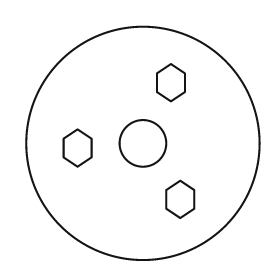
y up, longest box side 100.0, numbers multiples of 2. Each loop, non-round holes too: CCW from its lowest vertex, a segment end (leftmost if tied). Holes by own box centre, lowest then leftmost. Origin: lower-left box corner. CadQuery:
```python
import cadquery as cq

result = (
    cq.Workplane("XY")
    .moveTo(50.0, 50.0)
    .circle(50.0)
    .moveTo(66.0, 18.0)
    .lineTo(72.0, 22.0)
    .lineTo(72.0, 30.0)
    .lineTo(66.0, 34.0)
    .lineTo(60.0, 30.0)
    .lineTo(60.0, 22.0)
    .close()
    .moveTo(22.0, 40.0)
    .lineTo(28.0, 44.0)
    .lineTo(28.0, 52.0)
    .lineTo(22.0, 56.0)
    .lineTo(16.0, 52.0)
    .lineTo(16.0, 44.0)
    .close()
    .moveTo(50.0, 50.0)
    .circle(10.0)
    .moveTo(62.0, 68.0)
    .lineTo(68.0, 72.0)
    .lineTo(68.0, 80.0)
    .lineTo(62.0, 84.0)
    .lineTo(56.0, 80.0)
    .lineTo(56.0, 72.0)
    .close()
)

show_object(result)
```